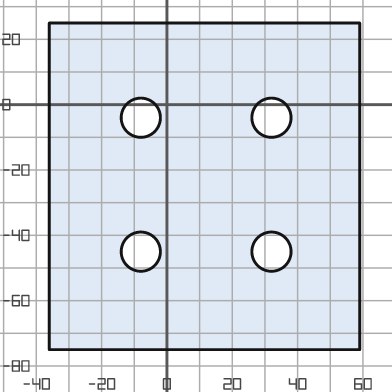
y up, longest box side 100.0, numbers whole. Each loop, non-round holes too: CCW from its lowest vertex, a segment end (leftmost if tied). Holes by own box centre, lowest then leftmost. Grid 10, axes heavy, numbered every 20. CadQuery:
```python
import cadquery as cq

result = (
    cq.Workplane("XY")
    .moveTo(-36.0, -75.0)
    .lineTo(59.0, -75.0)
    .lineTo(59.0, 25.0)
    .lineTo(-36.0, 25.0)
    .close()
    .moveTo(-8.0, -45.0)
    .circle(6.0)
    .moveTo(32.0, -45.0)
    .circle(6.0)
    .moveTo(-8.0, -4.0)
    .circle(6.0)
    .moveTo(32.0, -4.0)
    .circle(6.0)
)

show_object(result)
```